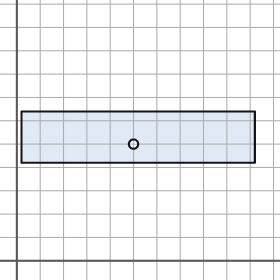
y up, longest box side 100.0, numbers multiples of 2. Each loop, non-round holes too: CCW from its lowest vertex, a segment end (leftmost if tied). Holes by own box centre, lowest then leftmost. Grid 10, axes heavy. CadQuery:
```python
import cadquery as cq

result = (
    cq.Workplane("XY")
    .moveTo(2.0, 42.0)
    .lineTo(102.0, 42.0)
    .lineTo(102.0, 64.0)
    .lineTo(2.0, 64.0)
    .close()
    .moveTo(50.0, 50.0)
    .circle(2.0)
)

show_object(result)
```